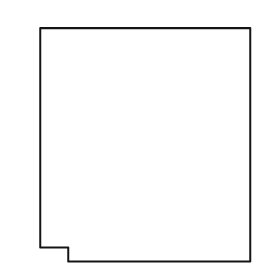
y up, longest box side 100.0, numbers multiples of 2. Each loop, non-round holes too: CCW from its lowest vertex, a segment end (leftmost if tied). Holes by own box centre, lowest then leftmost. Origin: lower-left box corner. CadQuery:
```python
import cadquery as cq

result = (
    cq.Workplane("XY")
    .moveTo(12.0, 0.0)
    .lineTo(90.0, 0.0)
    .lineTo(90.0, 100.0)
    .lineTo(0.0, 100.0)
    .lineTo(0.0, 6.0)
    .lineTo(12.0, 6.0)
    .close()
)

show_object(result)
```